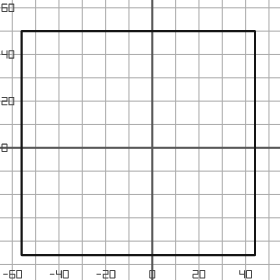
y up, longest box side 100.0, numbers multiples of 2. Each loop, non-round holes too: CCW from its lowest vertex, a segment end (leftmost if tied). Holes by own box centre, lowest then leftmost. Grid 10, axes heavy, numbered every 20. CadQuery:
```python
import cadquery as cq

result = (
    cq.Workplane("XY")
    .moveTo(-56.0, -46.0)
    .lineTo(44.0, -46.0)
    .lineTo(44.0, 50.0)
    .lineTo(-56.0, 50.0)
    .close()
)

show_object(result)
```